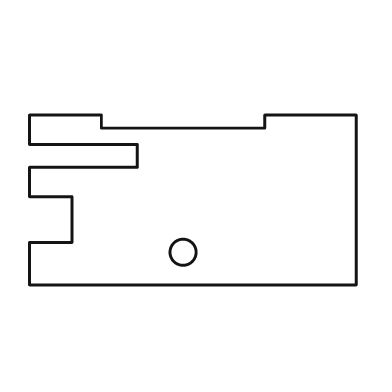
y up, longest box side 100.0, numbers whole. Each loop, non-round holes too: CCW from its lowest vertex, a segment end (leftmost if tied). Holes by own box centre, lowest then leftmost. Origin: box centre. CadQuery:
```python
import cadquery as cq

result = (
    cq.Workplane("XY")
    .moveTo(-50.0, -26.0)
    .lineTo(50.0, -26.0)
    .lineTo(50.0, 26.0)
    .lineTo(22.0, 26.0)
    .lineTo(22.0, 22.0)
    .lineTo(-28.0, 22.0)
    .lineTo(-28.0, 26.0)
    .lineTo(-50.0, 26.0)
    .lineTo(-50.0, 17.0)
    .lineTo(-17.0, 17.0)
    .lineTo(-17.0, 10.0)
    .lineTo(-50.0, 10.0)
    .lineTo(-50.0, 1.0)
    .lineTo(-37.0, 1.0)
    .lineTo(-37.0, -13.0)
    .lineTo(-50.0, -13.0)
    .close()
    .moveTo(-3.0, -16.0)
    .circle(4.0)
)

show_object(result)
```